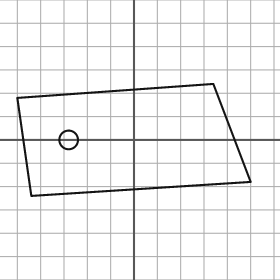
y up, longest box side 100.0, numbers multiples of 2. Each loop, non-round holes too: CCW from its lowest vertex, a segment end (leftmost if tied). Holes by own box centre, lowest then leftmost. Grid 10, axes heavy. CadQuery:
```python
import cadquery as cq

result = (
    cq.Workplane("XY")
    .moveTo(-44.0, -24.0)
    .lineTo(50.0, -18.0)
    .lineTo(34.0, 24.0)
    .lineTo(-50.0, 18.0)
    .close()
    .moveTo(-28.0, 0.0)
    .circle(4.0)
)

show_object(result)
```